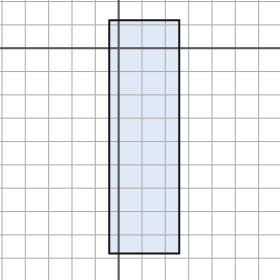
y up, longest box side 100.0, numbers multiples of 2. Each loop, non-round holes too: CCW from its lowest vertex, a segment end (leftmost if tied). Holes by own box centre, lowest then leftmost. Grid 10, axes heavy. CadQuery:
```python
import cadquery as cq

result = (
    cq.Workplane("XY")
    .moveTo(-4.0, -88.0)
    .lineTo(26.0, -88.0)
    .lineTo(26.0, 12.0)
    .lineTo(-4.0, 12.0)
    .close()
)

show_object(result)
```